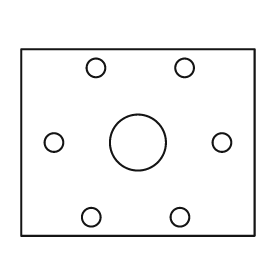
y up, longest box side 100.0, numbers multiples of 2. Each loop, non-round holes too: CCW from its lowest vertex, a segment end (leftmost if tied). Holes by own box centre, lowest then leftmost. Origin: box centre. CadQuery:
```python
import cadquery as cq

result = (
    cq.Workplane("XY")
    .moveTo(-50.0, -40.0)
    .lineTo(50.0, -40.0)
    .lineTo(50.0, 40.0)
    .lineTo(-50.0, 40.0)
    .close()
    .moveTo(-20.0, -32.0)
    .circle(4.0)
    .moveTo(18.0, -32.0)
    .circle(4.0)
    .moveTo(-36.0, 0.0)
    .circle(4.0)
    .moveTo(0.0, 0.0)
    .circle(12.0)
    .moveTo(36.0, 0.0)
    .circle(4.0)
    .moveTo(-18.0, 32.0)
    .circle(4.0)
    .moveTo(20.0, 32.0)
    .circle(4.0)
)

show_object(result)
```